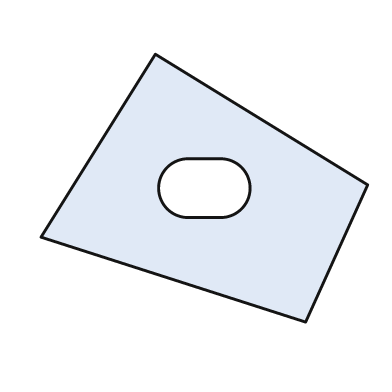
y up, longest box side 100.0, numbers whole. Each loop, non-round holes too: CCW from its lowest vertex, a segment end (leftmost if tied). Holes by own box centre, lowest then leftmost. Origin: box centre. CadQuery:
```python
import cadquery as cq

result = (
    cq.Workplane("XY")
    .moveTo(31.0, -41.0)
    .lineTo(50.0, 1.0)
    .lineTo(-15.0, 41.0)
    .lineTo(-50.0, -15.0)
    .close()
    .moveTo(-5.0, -9.0)
    .lineTo(5.0, -9.0)
    .threePointArc((14.0, 0.0), (5.0, 9.0))
    .lineTo(-5.0, 9.0)
    .threePointArc((-14.0, 0.0), (-5.0, -9.0))
    .close()
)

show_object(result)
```